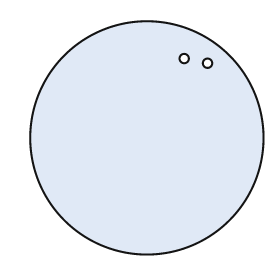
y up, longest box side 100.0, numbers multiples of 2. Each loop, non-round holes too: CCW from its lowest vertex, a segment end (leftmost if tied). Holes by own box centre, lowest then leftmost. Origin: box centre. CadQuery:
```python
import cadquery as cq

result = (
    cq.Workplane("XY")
    .moveTo(0.0, 0.0)
    .circle(50.0)
    .moveTo(26.0, 32.0)
    .circle(2.0)
    .moveTo(16.0, 34.0)
    .circle(2.0)
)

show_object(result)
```